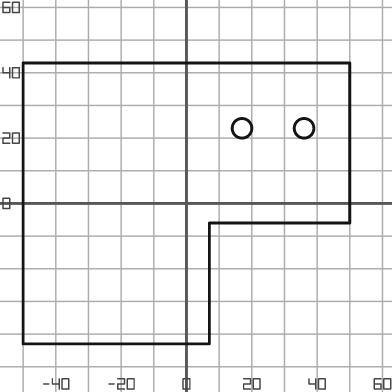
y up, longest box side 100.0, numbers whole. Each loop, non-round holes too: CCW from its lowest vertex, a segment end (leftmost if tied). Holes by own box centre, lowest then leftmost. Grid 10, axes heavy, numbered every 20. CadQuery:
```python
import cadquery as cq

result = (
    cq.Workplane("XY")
    .moveTo(-50.0, -43.0)
    .lineTo(7.0, -43.0)
    .lineTo(7.0, -6.0)
    .lineTo(50.0, -6.0)
    .lineTo(50.0, 43.0)
    .lineTo(-50.0, 43.0)
    .close()
    .moveTo(17.0, 23.0)
    .circle(3.0)
    .moveTo(36.0, 23.0)
    .circle(3.0)
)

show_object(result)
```